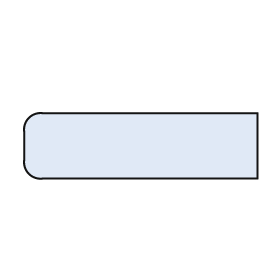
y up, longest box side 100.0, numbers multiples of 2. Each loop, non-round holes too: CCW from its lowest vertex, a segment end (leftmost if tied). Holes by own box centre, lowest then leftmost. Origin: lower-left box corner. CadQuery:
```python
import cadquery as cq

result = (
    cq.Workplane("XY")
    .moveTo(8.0, 0.0)
    .lineTo(100.0, 0.0)
    .lineTo(100.0, 28.0)
    .lineTo(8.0, 28.0)
    .threePointArc((2.0, 26.0), (0.0, 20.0))
    .lineTo(0.0, 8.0)
    .threePointArc((2.0, 2.0), (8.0, 0.0))
    .close()
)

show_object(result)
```